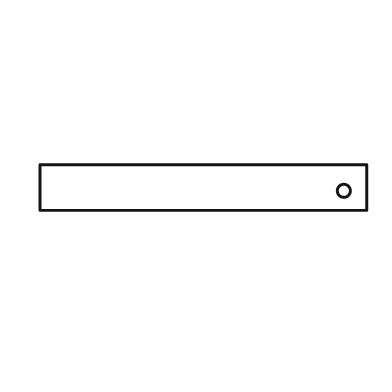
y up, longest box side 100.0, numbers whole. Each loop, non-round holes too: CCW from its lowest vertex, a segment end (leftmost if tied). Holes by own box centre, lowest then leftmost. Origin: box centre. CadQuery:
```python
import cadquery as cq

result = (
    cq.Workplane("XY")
    .moveTo(-50.0, -7.0)
    .lineTo(50.0, -7.0)
    .lineTo(50.0, 7.0)
    .lineTo(-50.0, 7.0)
    .close()
    .moveTo(43.0, -1.0)
    .circle(2.0)
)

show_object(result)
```